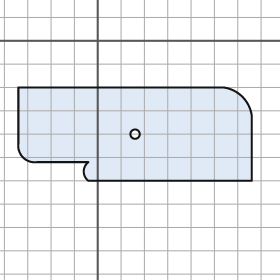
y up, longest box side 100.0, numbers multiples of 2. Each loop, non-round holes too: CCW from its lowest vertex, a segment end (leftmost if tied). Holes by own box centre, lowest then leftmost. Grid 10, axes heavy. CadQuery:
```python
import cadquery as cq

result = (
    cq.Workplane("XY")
    .moveTo(-4.0, -60.0)
    .lineTo(66.0, -60.0)
    .lineTo(66.0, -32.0)
    .threePointArc((62.0, -24.0), (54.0, -20.0))
    .lineTo(-34.0, -20.0)
    .lineTo(-34.0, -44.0)
    .threePointArc((-32.0, -50.0), (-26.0, -52.0))
    .lineTo(-4.0, -52.0)
    .threePointArc((-6.0, -56.0), (-4.0, -60.0))
    .close()
    .moveTo(16.0, -40.0)
    .circle(2.0)
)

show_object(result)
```